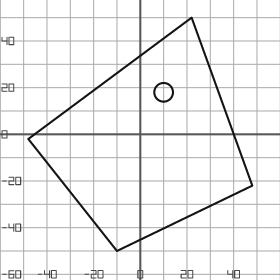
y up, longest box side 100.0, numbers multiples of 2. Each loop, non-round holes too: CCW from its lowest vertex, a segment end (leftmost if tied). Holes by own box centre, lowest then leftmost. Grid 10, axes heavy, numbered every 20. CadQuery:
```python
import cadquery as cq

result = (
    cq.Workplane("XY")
    .moveTo(-10.0, -50.0)
    .lineTo(48.0, -22.0)
    .lineTo(22.0, 50.0)
    .lineTo(-48.0, -2.0)
    .close()
    .moveTo(10.0, 18.0)
    .circle(4.0)
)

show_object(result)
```